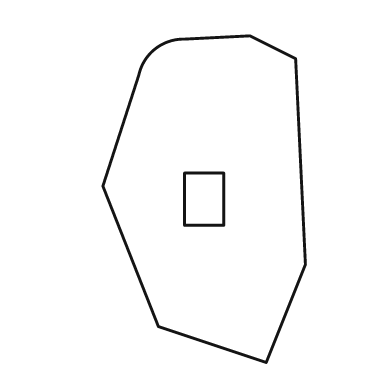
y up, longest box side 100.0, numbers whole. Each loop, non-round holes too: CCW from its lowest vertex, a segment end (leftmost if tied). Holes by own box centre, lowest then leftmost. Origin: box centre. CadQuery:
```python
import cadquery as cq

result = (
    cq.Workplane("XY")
    .moveTo(19.0, -50.0)
    .lineTo(31.0, -20.0)
    .lineTo(28.0, 43.0)
    .lineTo(14.0, 50.0)
    .lineTo(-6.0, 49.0)
    .threePointArc((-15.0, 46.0), (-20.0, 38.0))
    .lineTo(-31.0, 4.0)
    .lineTo(-14.0, -39.0)
    .close()
    .moveTo(-6.0, -8.0)
    .lineTo(6.0, -8.0)
    .lineTo(6.0, 8.0)
    .lineTo(-6.0, 8.0)
    .close()
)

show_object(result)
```